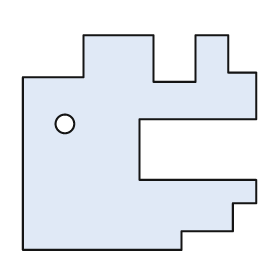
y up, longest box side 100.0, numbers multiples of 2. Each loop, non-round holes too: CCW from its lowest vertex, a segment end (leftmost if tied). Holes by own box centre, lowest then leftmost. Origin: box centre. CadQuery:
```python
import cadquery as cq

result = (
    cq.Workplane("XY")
    .moveTo(-50.0, -46.0)
    .lineTo(18.0, -46.0)
    .lineTo(18.0, -38.0)
    .lineTo(40.0, -38.0)
    .lineTo(40.0, -26.0)
    .lineTo(50.0, -26.0)
    .lineTo(50.0, -16.0)
    .lineTo(0.0, -16.0)
    .lineTo(0.0, 10.0)
    .lineTo(50.0, 10.0)
    .lineTo(50.0, 30.0)
    .lineTo(38.0, 30.0)
    .lineTo(38.0, 46.0)
    .lineTo(24.0, 46.0)
    .lineTo(24.0, 26.0)
    .lineTo(6.0, 26.0)
    .lineTo(6.0, 46.0)
    .lineTo(-24.0, 46.0)
    .lineTo(-24.0, 28.0)
    .lineTo(-50.0, 28.0)
    .close()
    .moveTo(-32.0, 8.0)
    .circle(4.0)
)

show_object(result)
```